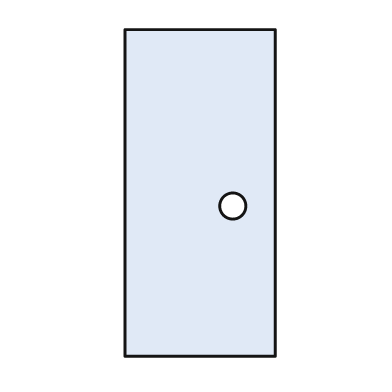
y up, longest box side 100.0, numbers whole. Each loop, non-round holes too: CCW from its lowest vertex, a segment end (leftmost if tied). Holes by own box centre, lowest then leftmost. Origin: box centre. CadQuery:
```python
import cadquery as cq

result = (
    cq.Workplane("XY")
    .moveTo(-23.0, -50.0)
    .lineTo(23.0, -50.0)
    .lineTo(23.0, 50.0)
    .lineTo(-23.0, 50.0)
    .close()
    .moveTo(10.0, -4.0)
    .circle(4.0)
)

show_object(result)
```